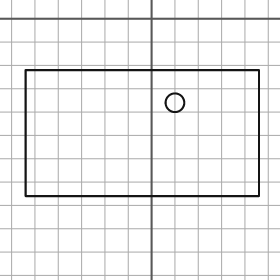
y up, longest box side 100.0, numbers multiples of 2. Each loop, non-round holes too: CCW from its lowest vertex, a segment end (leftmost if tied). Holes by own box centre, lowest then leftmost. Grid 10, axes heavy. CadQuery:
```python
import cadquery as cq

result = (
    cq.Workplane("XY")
    .moveTo(-54.0, -76.0)
    .lineTo(46.0, -76.0)
    .lineTo(46.0, -22.0)
    .lineTo(-54.0, -22.0)
    .close()
    .moveTo(10.0, -36.0)
    .circle(4.0)
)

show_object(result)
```